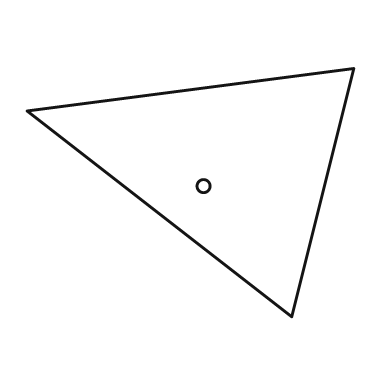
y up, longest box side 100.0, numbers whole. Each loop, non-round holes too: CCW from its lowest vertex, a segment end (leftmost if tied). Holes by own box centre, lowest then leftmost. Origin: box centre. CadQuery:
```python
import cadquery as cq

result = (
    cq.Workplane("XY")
    .moveTo(31.0, -38.0)
    .lineTo(50.0, 38.0)
    .lineTo(-50.0, 25.0)
    .close()
    .moveTo(4.0, 2.0)
    .circle(2.0)
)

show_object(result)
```